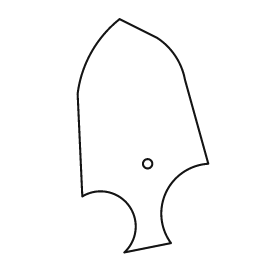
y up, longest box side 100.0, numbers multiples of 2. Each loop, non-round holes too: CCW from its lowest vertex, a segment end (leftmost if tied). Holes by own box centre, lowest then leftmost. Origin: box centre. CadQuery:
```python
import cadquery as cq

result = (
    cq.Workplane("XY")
    .moveTo(-8.0, -50.0)
    .lineTo(12.0, -46.0)
    .threePointArc((10.0, -24.0), (28.0, -12.0))
    .lineTo(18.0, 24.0)
    .threePointArc((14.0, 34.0), (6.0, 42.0))
    .lineTo(-10.0, 50.0)
    .threePointArc((-22.0, 36.0), (-28.0, 18.0))
    .lineTo(-26.0, -26.0)
    .threePointArc((-6.0, -30.0), (-8.0, -50.0))
    .close()
    .moveTo(2.0, -12.0)
    .circle(2.0)
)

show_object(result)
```